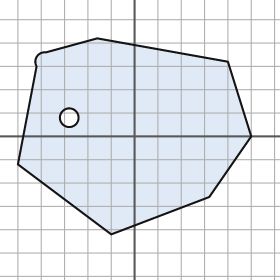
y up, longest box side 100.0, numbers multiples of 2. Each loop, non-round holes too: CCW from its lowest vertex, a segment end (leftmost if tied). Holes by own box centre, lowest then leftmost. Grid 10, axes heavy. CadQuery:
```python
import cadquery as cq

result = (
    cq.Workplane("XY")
    .moveTo(-10.0, -42.0)
    .lineTo(32.0, -26.0)
    .lineTo(50.0, 0.0)
    .lineTo(40.0, 32.0)
    .lineTo(-16.0, 42.0)
    .lineTo(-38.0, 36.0)
    .threePointArc((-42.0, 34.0), (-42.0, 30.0))
    .lineTo(-50.0, -12.0)
    .close()
    .moveTo(-28.0, 8.0)
    .circle(4.0)
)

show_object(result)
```